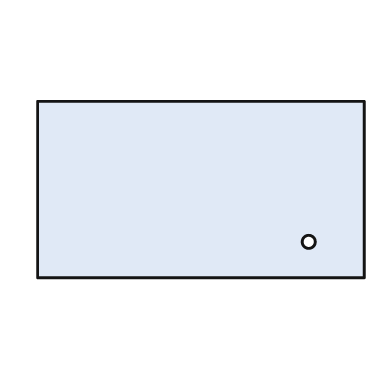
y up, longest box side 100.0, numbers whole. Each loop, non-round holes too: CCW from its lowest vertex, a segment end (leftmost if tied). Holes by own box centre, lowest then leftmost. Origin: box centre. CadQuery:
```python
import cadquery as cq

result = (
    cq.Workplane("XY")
    .moveTo(-50.0, -27.0)
    .lineTo(50.0, -27.0)
    .lineTo(50.0, 27.0)
    .lineTo(-50.0, 27.0)
    .close()
    .moveTo(33.0, -16.0)
    .circle(2.0)
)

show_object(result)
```